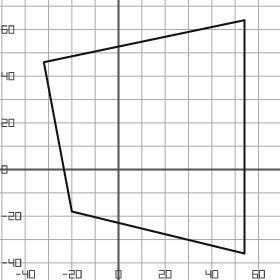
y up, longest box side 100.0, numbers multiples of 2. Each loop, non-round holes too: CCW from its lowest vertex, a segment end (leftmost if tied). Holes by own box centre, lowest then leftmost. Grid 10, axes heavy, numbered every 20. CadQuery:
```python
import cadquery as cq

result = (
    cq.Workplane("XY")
    .moveTo(54.0, -36.0)
    .lineTo(54.0, 64.0)
    .lineTo(-32.0, 46.0)
    .lineTo(-20.0, -18.0)
    .close()
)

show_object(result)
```